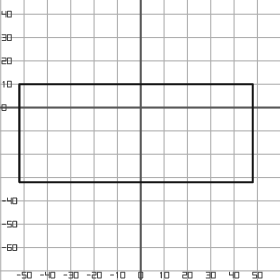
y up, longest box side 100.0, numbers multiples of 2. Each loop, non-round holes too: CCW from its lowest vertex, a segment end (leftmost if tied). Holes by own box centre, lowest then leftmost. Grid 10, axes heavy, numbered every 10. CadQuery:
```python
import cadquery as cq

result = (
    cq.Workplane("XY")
    .moveTo(-52.0, -32.0)
    .lineTo(48.0, -32.0)
    .lineTo(48.0, 10.0)
    .lineTo(-52.0, 10.0)
    .close()
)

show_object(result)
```